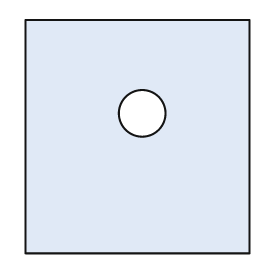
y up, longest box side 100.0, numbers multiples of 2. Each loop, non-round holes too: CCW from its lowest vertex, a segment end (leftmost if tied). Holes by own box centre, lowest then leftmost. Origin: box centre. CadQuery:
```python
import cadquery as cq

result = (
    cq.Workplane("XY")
    .moveTo(-48.0, -50.0)
    .lineTo(48.0, -50.0)
    .lineTo(48.0, 50.0)
    .lineTo(-48.0, 50.0)
    .close()
    .moveTo(2.0, 10.0)
    .circle(10.0)
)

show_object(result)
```